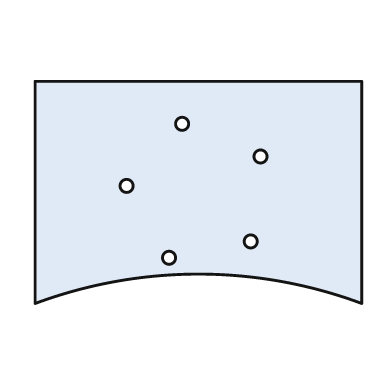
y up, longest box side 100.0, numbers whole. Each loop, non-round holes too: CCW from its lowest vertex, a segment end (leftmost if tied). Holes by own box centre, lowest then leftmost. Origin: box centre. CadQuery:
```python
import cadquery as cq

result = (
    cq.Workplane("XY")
    .moveTo(-50.0, -34.0)
    .threePointArc((0.0, -25.0), (50.0, -34.0))
    .lineTo(50.0, 34.0)
    .lineTo(-50.0, 34.0)
    .close()
    .moveTo(-9.0, -20.0)
    .circle(2.0)
    .moveTo(16.0, -15.0)
    .circle(2.0)
    .moveTo(-22.0, 2.0)
    .circle(2.0)
    .moveTo(19.0, 11.0)
    .circle(2.0)
    .moveTo(-5.0, 21.0)
    .circle(2.0)
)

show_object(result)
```